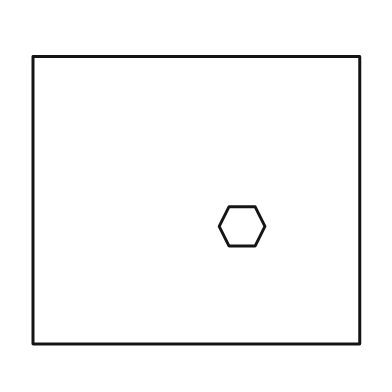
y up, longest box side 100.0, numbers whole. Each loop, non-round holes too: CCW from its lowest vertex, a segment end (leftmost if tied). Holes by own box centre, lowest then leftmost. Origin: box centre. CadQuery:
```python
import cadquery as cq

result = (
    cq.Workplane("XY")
    .moveTo(-50.0, -44.0)
    .lineTo(50.0, -44.0)
    .lineTo(50.0, 44.0)
    .lineTo(-50.0, 44.0)
    .close()
    .moveTo(10.0, -14.0)
    .lineTo(18.0, -14.0)
    .lineTo(21.0, -8.0)
    .lineTo(18.0, -2.0)
    .lineTo(10.0, -2.0)
    .lineTo(7.0, -8.0)
    .close()
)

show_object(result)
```